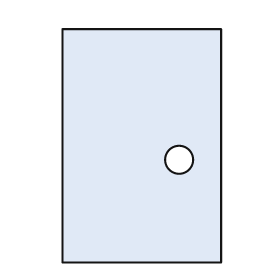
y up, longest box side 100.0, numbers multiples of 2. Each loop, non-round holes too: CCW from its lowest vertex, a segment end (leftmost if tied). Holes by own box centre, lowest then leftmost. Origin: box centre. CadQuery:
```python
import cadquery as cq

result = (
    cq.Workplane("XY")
    .moveTo(-34.0, -50.0)
    .lineTo(34.0, -50.0)
    .lineTo(34.0, 50.0)
    .lineTo(-34.0, 50.0)
    .close()
    .moveTo(16.0, -6.0)
    .circle(6.0)
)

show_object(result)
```